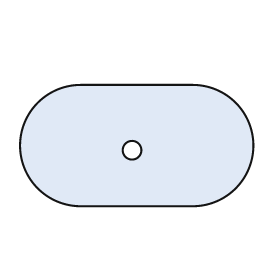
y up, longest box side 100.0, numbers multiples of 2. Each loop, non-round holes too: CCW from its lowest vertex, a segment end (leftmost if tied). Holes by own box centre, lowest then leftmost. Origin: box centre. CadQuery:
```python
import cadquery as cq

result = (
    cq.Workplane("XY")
    .moveTo(-24.0, -26.0)
    .lineTo(24.0, -26.0)
    .threePointArc((50.0, 0.0), (24.0, 26.0))
    .lineTo(-24.0, 26.0)
    .threePointArc((-50.0, 0.0), (-24.0, -26.0))
    .close()
    .moveTo(-2.0, -2.0)
    .circle(4.0)
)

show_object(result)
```